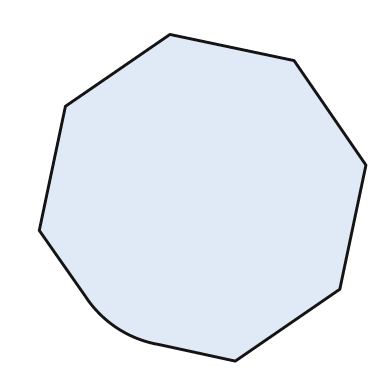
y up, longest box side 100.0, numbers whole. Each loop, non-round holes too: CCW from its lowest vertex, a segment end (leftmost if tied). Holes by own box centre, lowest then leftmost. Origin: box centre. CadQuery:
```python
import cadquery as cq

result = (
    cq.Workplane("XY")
    .moveTo(10.0, -50.0)
    .lineTo(42.0, -28.0)
    .lineTo(50.0, 10.0)
    .lineTo(28.0, 42.0)
    .lineTo(-10.0, 50.0)
    .lineTo(-42.0, 28.0)
    .lineTo(-50.0, -10.0)
    .lineTo(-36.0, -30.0)
    .threePointArc((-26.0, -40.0), (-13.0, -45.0))
    .close()
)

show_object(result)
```